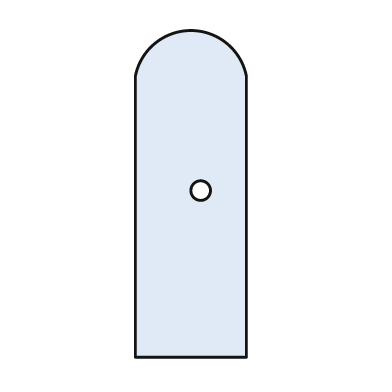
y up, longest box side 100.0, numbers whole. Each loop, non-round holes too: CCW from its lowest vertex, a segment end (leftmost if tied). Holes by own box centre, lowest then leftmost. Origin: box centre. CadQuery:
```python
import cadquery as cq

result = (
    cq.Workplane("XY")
    .moveTo(-17.0, -50.0)
    .lineTo(17.0, -50.0)
    .lineTo(17.0, 36.0)
    .threePointArc((0.0, 50.0), (-17.0, 36.0))
    .close()
    .moveTo(3.0, 1.0)
    .circle(3.0)
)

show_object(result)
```